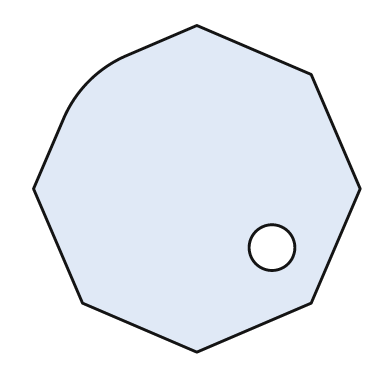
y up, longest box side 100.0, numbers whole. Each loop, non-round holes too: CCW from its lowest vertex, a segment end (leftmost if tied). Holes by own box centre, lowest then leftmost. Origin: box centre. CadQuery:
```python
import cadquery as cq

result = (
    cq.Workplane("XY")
    .moveTo(0.0, -50.0)
    .lineTo(35.0, -35.0)
    .lineTo(50.0, 0.0)
    .lineTo(35.0, 35.0)
    .lineTo(0.0, 50.0)
    .lineTo(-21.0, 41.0)
    .threePointArc((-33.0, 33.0), (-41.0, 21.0))
    .lineTo(-50.0, 0.0)
    .lineTo(-35.0, -35.0)
    .close()
    .moveTo(23.0, -18.0)
    .circle(7.0)
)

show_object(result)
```